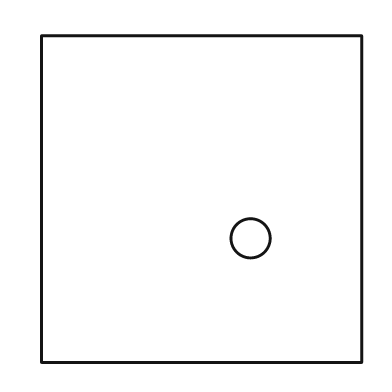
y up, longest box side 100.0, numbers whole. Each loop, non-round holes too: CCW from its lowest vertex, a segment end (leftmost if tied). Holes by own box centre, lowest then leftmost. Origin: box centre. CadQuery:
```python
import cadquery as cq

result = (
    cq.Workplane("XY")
    .moveTo(-49.0, -50.0)
    .lineTo(49.0, -50.0)
    .lineTo(49.0, 50.0)
    .lineTo(-49.0, 50.0)
    .close()
    .moveTo(15.0, -12.0)
    .circle(6.0)
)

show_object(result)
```